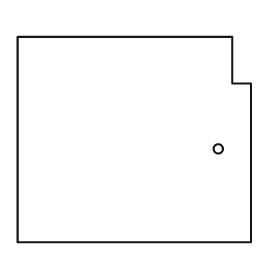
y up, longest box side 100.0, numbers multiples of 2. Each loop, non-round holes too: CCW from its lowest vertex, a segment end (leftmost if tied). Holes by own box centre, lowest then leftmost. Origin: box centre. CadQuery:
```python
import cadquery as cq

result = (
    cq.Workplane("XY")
    .moveTo(-50.0, -44.0)
    .lineTo(50.0, -44.0)
    .lineTo(50.0, 24.0)
    .lineTo(42.0, 24.0)
    .lineTo(42.0, 44.0)
    .lineTo(-50.0, 44.0)
    .close()
    .moveTo(36.0, -4.0)
    .circle(2.0)
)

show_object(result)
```